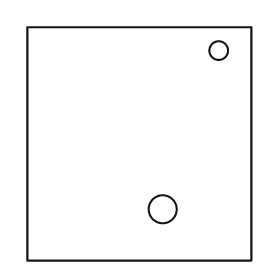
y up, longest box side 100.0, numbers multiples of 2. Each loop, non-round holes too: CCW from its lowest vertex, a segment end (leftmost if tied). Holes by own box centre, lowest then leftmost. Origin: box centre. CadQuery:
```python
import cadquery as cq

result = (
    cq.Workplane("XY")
    .moveTo(-48.0, -50.0)
    .lineTo(48.0, -50.0)
    .lineTo(48.0, 50.0)
    .lineTo(-48.0, 50.0)
    .close()
    .moveTo(10.0, -28.0)
    .circle(6.0)
    .moveTo(34.0, 40.0)
    .circle(4.0)
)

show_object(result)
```